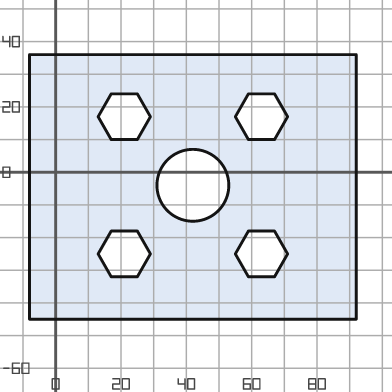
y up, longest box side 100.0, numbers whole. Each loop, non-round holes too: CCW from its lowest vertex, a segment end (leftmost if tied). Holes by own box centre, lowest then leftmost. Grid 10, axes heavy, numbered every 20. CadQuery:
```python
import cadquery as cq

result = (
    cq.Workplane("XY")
    .moveTo(-8.0, -45.0)
    .lineTo(92.0, -45.0)
    .lineTo(92.0, 36.0)
    .lineTo(-8.0, 36.0)
    .close()
    .moveTo(17.0, -32.0)
    .lineTo(25.0, -32.0)
    .lineTo(29.0, -25.0)
    .lineTo(25.0, -18.0)
    .lineTo(17.0, -18.0)
    .lineTo(13.0, -25.0)
    .close()
    .moveTo(59.0, -32.0)
    .lineTo(67.0, -32.0)
    .lineTo(71.0, -25.0)
    .lineTo(67.0, -18.0)
    .lineTo(59.0, -18.0)
    .lineTo(55.0, -25.0)
    .close()
    .moveTo(42.0, -4.0)
    .circle(11.0)
    .moveTo(17.0, 10.0)
    .lineTo(25.0, 10.0)
    .lineTo(29.0, 17.0)
    .lineTo(25.0, 24.0)
    .lineTo(17.0, 24.0)
    .lineTo(13.0, 17.0)
    .close()
    .moveTo(59.0, 10.0)
    .lineTo(67.0, 10.0)
    .lineTo(71.0, 17.0)
    .lineTo(67.0, 24.0)
    .lineTo(59.0, 24.0)
    .lineTo(55.0, 17.0)
    .close()
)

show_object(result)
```